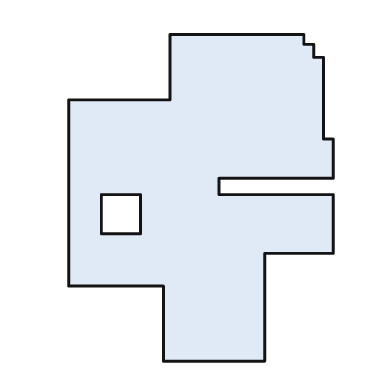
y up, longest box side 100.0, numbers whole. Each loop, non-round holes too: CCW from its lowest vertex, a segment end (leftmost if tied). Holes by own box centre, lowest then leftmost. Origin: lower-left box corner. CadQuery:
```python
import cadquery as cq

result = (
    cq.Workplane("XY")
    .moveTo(29.0, 0.0)
    .lineTo(60.0, 0.0)
    .lineTo(60.0, 33.0)
    .lineTo(81.0, 33.0)
    .lineTo(81.0, 51.0)
    .lineTo(46.0, 51.0)
    .lineTo(46.0, 56.0)
    .lineTo(81.0, 56.0)
    .lineTo(81.0, 68.0)
    .lineTo(78.0, 68.0)
    .lineTo(78.0, 93.0)
    .lineTo(75.0, 93.0)
    .lineTo(75.0, 97.0)
    .lineTo(72.0, 97.0)
    .lineTo(72.0, 100.0)
    .lineTo(31.0, 100.0)
    .lineTo(31.0, 80.0)
    .lineTo(0.0, 80.0)
    .lineTo(0.0, 23.0)
    .lineTo(29.0, 23.0)
    .close()
    .moveTo(10.0, 39.0)
    .lineTo(22.0, 39.0)
    .lineTo(22.0, 51.0)
    .lineTo(10.0, 51.0)
    .close()
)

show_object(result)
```